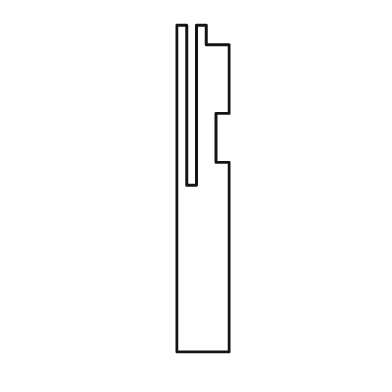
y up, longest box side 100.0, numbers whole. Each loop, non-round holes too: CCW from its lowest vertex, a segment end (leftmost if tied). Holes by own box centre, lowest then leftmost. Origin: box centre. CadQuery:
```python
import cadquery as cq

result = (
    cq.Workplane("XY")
    .moveTo(-8.0, -50.0)
    .lineTo(8.0, -50.0)
    .lineTo(8.0, 8.0)
    .lineTo(4.0, 8.0)
    .lineTo(4.0, 23.0)
    .lineTo(8.0, 23.0)
    .lineTo(8.0, 44.0)
    .lineTo(1.0, 44.0)
    .lineTo(1.0, 50.0)
    .lineTo(-2.0, 50.0)
    .lineTo(-2.0, 1.0)
    .lineTo(-5.0, 1.0)
    .lineTo(-5.0, 50.0)
    .lineTo(-8.0, 50.0)
    .close()
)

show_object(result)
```